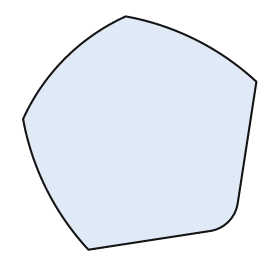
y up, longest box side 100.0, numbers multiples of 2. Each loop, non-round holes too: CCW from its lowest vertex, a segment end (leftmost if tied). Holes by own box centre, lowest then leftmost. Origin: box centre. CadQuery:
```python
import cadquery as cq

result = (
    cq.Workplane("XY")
    .moveTo(-22.0, -50.0)
    .lineTo(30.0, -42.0)
    .threePointArc((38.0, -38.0), (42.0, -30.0))
    .lineTo(50.0, 22.0)
    .threePointArc((24.0, 40.0), (-6.0, 50.0))
    .threePointArc((-32.0, 32.0), (-50.0, 6.0))
    .threePointArc((-40.0, -24.0), (-22.0, -50.0))
    .close()
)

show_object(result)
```